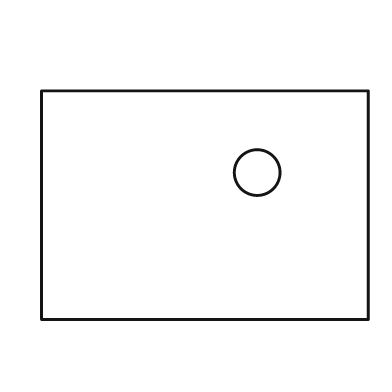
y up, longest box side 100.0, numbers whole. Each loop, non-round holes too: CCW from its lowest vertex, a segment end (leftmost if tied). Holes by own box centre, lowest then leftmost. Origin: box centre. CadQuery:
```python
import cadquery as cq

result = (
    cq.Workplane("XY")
    .moveTo(-50.0, -35.0)
    .lineTo(50.0, -35.0)
    .lineTo(50.0, 35.0)
    .lineTo(-50.0, 35.0)
    .close()
    .moveTo(16.0, 10.0)
    .circle(7.0)
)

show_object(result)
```